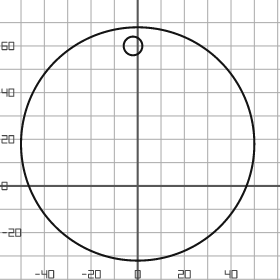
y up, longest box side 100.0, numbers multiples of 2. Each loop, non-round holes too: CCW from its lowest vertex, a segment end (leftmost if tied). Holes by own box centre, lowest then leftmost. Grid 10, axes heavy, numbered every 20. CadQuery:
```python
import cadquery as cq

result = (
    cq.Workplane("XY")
    .moveTo(0.0, 18.0)
    .circle(50.0)
    .moveTo(-2.0, 60.0)
    .circle(4.0)
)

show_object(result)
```